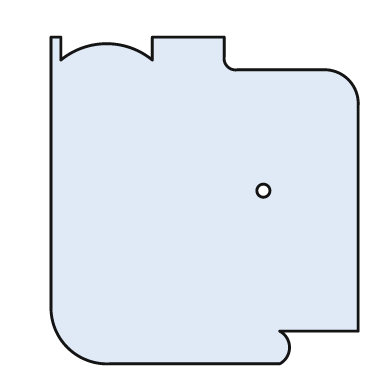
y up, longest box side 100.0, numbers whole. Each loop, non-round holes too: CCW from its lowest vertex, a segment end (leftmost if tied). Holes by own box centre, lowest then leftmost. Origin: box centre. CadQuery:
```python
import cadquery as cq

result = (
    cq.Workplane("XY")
    .moveTo(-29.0, -50.0)
    .lineTo(23.0, -50.0)
    .threePointArc((26.0, -45.0), (23.0, -40.0))
    .lineTo(47.0, -40.0)
    .lineTo(47.0, 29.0)
    .threePointArc((44.0, 37.0), (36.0, 40.0))
    .lineTo(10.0, 40.0)
    .threePointArc((7.0, 41.0), (6.0, 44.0))
    .lineTo(6.0, 50.0)
    .lineTo(-16.0, 50.0)
    .lineTo(-16.0, 43.0)
    .threePointArc((-30.0, 48.0), (-44.0, 43.0))
    .lineTo(-44.0, 50.0)
    .lineTo(-47.0, 50.0)
    .lineTo(-47.0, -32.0)
    .threePointArc((-42.0, -45.0), (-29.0, -50.0))
    .close()
    .moveTo(18.0, 3.0)
    .circle(2.0)
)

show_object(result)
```